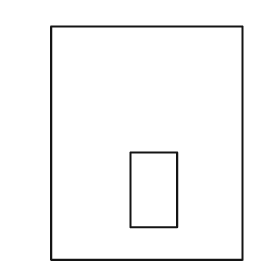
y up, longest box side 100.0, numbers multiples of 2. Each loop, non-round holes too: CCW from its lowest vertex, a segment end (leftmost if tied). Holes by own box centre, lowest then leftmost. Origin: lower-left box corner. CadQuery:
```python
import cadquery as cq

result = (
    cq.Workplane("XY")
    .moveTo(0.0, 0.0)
    .lineTo(82.0, 0.0)
    .lineTo(82.0, 100.0)
    .lineTo(0.0, 100.0)
    .close()
    .moveTo(34.0, 14.0)
    .lineTo(54.0, 14.0)
    .lineTo(54.0, 46.0)
    .lineTo(34.0, 46.0)
    .close()
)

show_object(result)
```